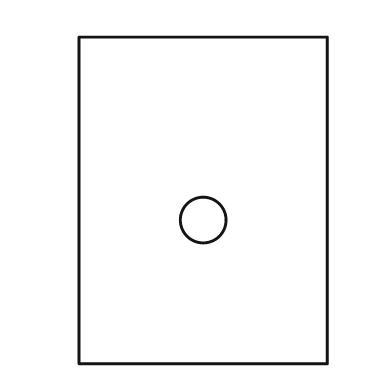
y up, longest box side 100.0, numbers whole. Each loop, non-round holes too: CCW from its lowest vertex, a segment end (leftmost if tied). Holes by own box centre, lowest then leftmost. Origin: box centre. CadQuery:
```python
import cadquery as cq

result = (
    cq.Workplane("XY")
    .moveTo(-38.0, -50.0)
    .lineTo(38.0, -50.0)
    .lineTo(38.0, 50.0)
    .lineTo(-38.0, 50.0)
    .close()
    .moveTo(0.0, -6.0)
    .circle(7.0)
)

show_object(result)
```